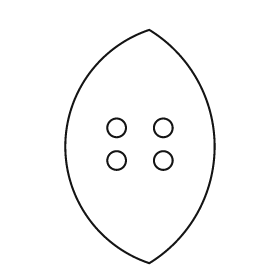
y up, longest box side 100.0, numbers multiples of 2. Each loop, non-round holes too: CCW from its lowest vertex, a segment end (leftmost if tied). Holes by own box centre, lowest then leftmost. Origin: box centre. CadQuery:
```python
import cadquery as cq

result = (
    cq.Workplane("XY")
    .moveTo(4.0, -50.0)
    .threePointArc((32.0, 0.0), (4.0, 50.0))
    .threePointArc((-32.0, 0.0), (4.0, -50.0))
    .close()
    .moveTo(-10.0, -6.0)
    .circle(4.0)
    .moveTo(10.0, -6.0)
    .circle(4.0)
    .moveTo(-10.0, 8.0)
    .circle(4.0)
    .moveTo(10.0, 8.0)
    .circle(4.0)
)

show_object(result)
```